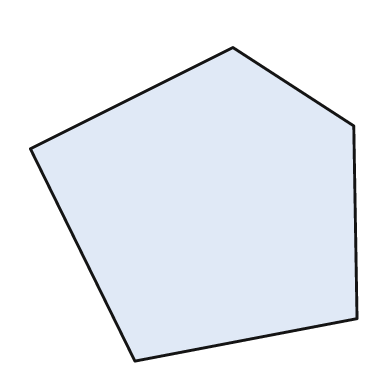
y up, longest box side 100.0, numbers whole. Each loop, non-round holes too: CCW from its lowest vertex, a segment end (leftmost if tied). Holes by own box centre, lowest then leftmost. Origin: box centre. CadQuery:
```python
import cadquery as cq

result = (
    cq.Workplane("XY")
    .moveTo(-18.0, -48.0)
    .lineTo(50.0, -35.0)
    .lineTo(49.0, 24.0)
    .lineTo(12.0, 48.0)
    .lineTo(-50.0, 17.0)
    .close()
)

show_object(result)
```